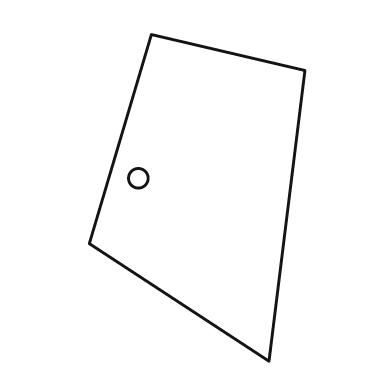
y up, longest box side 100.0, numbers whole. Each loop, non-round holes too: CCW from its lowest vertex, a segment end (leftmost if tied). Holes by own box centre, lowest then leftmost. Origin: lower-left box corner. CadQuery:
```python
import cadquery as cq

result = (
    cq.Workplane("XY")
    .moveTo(55.0, 0.0)
    .lineTo(66.0, 89.0)
    .lineTo(19.0, 100.0)
    .lineTo(0.0, 36.0)
    .close()
    .moveTo(15.0, 56.0)
    .circle(3.0)
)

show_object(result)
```